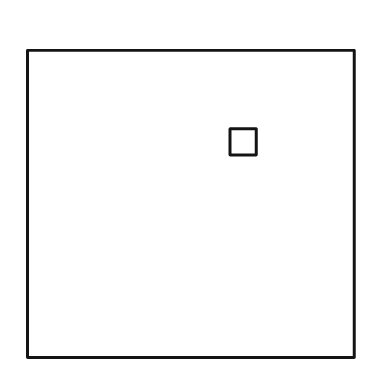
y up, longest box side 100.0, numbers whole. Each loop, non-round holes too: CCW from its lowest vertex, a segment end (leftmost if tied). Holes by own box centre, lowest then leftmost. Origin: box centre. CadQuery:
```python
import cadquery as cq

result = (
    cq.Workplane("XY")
    .moveTo(-50.0, -47.0)
    .lineTo(50.0, -47.0)
    .lineTo(50.0, 47.0)
    .lineTo(-50.0, 47.0)
    .close()
    .moveTo(12.0, 15.0)
    .lineTo(20.0, 15.0)
    .lineTo(20.0, 23.0)
    .lineTo(12.0, 23.0)
    .close()
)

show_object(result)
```